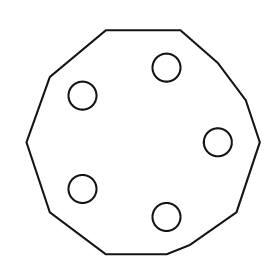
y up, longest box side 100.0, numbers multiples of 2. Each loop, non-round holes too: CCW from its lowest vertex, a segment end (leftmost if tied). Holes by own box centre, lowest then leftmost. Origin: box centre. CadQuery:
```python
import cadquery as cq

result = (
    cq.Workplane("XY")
    .moveTo(-16.0, -48.0)
    .lineTo(10.0, -48.0)
    .lineTo(20.0, -44.0)
    .lineTo(40.0, -30.0)
    .lineTo(50.0, 0.0)
    .lineTo(44.0, 18.0)
    .lineTo(32.0, 34.0)
    .lineTo(16.0, 48.0)
    .lineTo(-16.0, 48.0)
    .lineTo(-40.0, 28.0)
    .lineTo(-50.0, 0.0)
    .lineTo(-40.0, -30.0)
    .close()
    .moveTo(10.0, -32.0)
    .circle(6.0)
    .moveTo(-26.0, -20.0)
    .circle(6.0)
    .moveTo(32.0, 0.0)
    .circle(6.0)
    .moveTo(-26.0, 20.0)
    .circle(6.0)
    .moveTo(10.0, 32.0)
    .circle(6.0)
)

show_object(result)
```